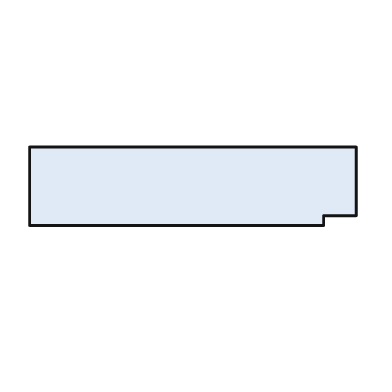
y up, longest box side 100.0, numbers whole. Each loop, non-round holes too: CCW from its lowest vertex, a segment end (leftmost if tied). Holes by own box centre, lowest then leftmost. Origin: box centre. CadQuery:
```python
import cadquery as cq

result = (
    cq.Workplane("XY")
    .moveTo(-50.0, -12.0)
    .lineTo(40.0, -12.0)
    .lineTo(40.0, -9.0)
    .lineTo(50.0, -9.0)
    .lineTo(50.0, 12.0)
    .lineTo(-50.0, 12.0)
    .close()
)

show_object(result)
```